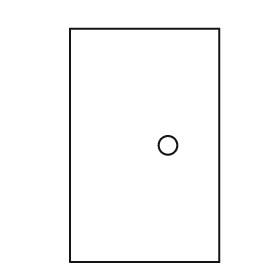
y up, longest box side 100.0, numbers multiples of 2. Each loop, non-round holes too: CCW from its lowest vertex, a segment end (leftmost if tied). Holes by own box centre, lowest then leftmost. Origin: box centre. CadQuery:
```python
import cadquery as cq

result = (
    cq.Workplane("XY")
    .moveTo(-32.0, -50.0)
    .lineTo(32.0, -50.0)
    .lineTo(32.0, 50.0)
    .lineTo(-32.0, 50.0)
    .close()
    .moveTo(10.0, 0.0)
    .circle(4.0)
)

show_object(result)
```